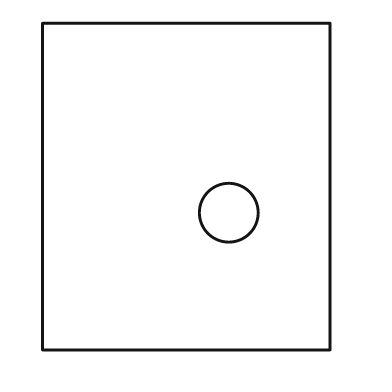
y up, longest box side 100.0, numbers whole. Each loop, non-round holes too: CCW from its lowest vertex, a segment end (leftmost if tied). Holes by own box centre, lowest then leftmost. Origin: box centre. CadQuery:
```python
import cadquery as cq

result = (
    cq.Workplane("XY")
    .moveTo(-44.0, -50.0)
    .lineTo(44.0, -50.0)
    .lineTo(44.0, 50.0)
    .lineTo(-44.0, 50.0)
    .close()
    .moveTo(13.0, -8.0)
    .circle(9.0)
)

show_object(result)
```